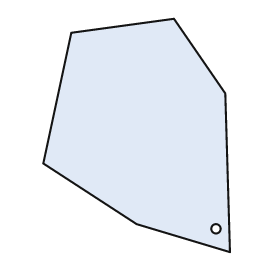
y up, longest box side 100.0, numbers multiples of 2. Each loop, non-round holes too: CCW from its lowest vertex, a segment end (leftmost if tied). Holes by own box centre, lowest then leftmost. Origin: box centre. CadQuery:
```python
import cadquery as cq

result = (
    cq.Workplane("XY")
    .moveTo(40.0, -50.0)
    .lineTo(38.0, 18.0)
    .lineTo(16.0, 50.0)
    .lineTo(-28.0, 44.0)
    .lineTo(-40.0, -12.0)
    .lineTo(0.0, -38.0)
    .close()
    .moveTo(34.0, -40.0)
    .circle(2.0)
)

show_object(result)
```